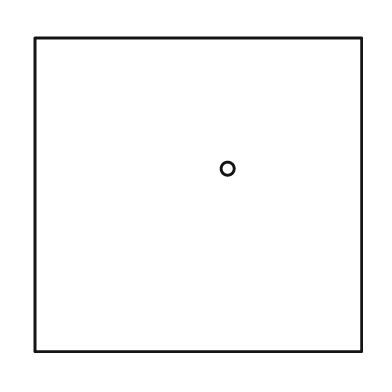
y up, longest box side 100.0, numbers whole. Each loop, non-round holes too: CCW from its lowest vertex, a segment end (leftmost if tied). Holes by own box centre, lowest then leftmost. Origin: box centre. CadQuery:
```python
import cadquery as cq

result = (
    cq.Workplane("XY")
    .moveTo(-50.0, -48.0)
    .lineTo(50.0, -48.0)
    .lineTo(50.0, 48.0)
    .lineTo(-50.0, 48.0)
    .close()
    .moveTo(9.0, 8.0)
    .circle(2.0)
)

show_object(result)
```